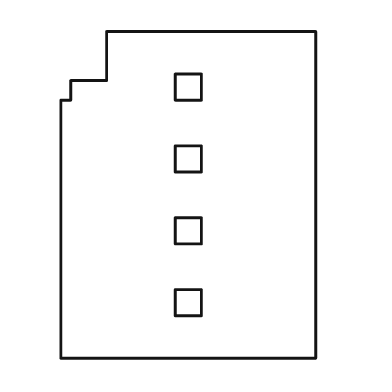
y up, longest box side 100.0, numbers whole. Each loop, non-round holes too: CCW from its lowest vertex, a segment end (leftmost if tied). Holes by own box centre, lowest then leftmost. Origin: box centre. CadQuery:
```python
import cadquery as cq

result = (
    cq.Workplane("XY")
    .moveTo(-39.0, -50.0)
    .lineTo(39.0, -50.0)
    .lineTo(39.0, 50.0)
    .lineTo(-25.0, 50.0)
    .lineTo(-25.0, 35.0)
    .lineTo(-36.0, 35.0)
    .lineTo(-36.0, 29.0)
    .lineTo(-39.0, 29.0)
    .close()
    .moveTo(-4.0, -37.0)
    .lineTo(4.0, -37.0)
    .lineTo(4.0, -29.0)
    .lineTo(-4.0, -29.0)
    .close()
    .moveTo(-4.0, -15.0)
    .lineTo(4.0, -15.0)
    .lineTo(4.0, -7.0)
    .lineTo(-4.0, -7.0)
    .close()
    .moveTo(-4.0, 7.0)
    .lineTo(4.0, 7.0)
    .lineTo(4.0, 15.0)
    .lineTo(-4.0, 15.0)
    .close()
    .moveTo(-4.0, 29.0)
    .lineTo(4.0, 29.0)
    .lineTo(4.0, 37.0)
    .lineTo(-4.0, 37.0)
    .close()
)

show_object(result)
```